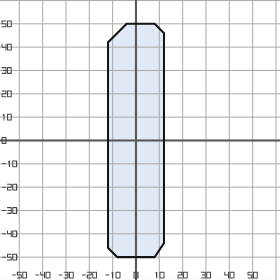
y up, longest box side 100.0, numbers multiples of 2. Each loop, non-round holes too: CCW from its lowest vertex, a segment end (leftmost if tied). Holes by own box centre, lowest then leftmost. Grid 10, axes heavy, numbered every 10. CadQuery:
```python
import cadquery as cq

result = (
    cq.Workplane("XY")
    .moveTo(-8.0, -50.0)
    .lineTo(8.0, -50.0)
    .lineTo(12.0, -44.0)
    .lineTo(12.0, 46.0)
    .lineTo(8.0, 50.0)
    .lineTo(-4.0, 50.0)
    .lineTo(-12.0, 42.0)
    .lineTo(-12.0, -46.0)
    .close()
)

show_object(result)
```